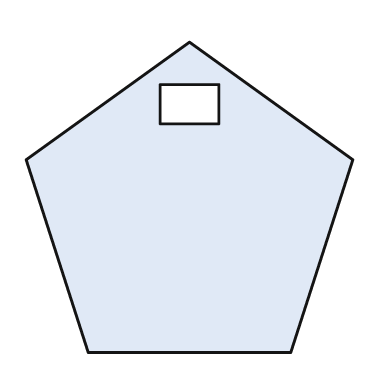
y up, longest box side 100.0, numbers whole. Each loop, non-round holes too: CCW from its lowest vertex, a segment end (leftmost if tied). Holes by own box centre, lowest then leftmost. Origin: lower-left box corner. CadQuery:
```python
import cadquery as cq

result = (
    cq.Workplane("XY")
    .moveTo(19.0, 0.0)
    .lineTo(81.0, 0.0)
    .lineTo(100.0, 59.0)
    .lineTo(50.0, 95.0)
    .lineTo(0.0, 59.0)
    .close()
    .moveTo(41.0, 70.0)
    .lineTo(59.0, 70.0)
    .lineTo(59.0, 82.0)
    .lineTo(41.0, 82.0)
    .close()
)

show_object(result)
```